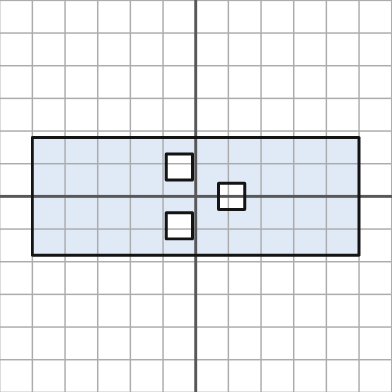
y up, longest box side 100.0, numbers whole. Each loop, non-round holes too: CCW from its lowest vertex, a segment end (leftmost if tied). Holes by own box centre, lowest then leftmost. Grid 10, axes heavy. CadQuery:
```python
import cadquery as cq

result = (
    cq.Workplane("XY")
    .moveTo(-50.0, -18.0)
    .lineTo(50.0, -18.0)
    .lineTo(50.0, 18.0)
    .lineTo(-50.0, 18.0)
    .close()
    .moveTo(-9.0, -13.0)
    .lineTo(-1.0, -13.0)
    .lineTo(-1.0, -5.0)
    .lineTo(-9.0, -5.0)
    .close()
    .moveTo(7.0, -4.0)
    .lineTo(15.0, -4.0)
    .lineTo(15.0, 4.0)
    .lineTo(7.0, 4.0)
    .close()
    .moveTo(-9.0, 5.0)
    .lineTo(-1.0, 5.0)
    .lineTo(-1.0, 13.0)
    .lineTo(-9.0, 13.0)
    .close()
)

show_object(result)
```